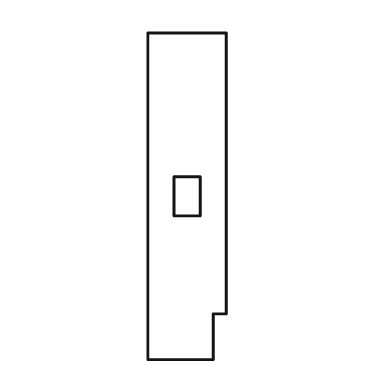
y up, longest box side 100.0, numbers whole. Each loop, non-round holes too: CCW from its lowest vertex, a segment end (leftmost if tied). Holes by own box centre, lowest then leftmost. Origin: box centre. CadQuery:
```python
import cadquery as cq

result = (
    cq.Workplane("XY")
    .moveTo(-12.0, -50.0)
    .lineTo(8.0, -50.0)
    .lineTo(8.0, -36.0)
    .lineTo(12.0, -36.0)
    .lineTo(12.0, 50.0)
    .lineTo(-12.0, 50.0)
    .close()
    .moveTo(-4.0, -6.0)
    .lineTo(4.0, -6.0)
    .lineTo(4.0, 6.0)
    .lineTo(-4.0, 6.0)
    .close()
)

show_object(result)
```